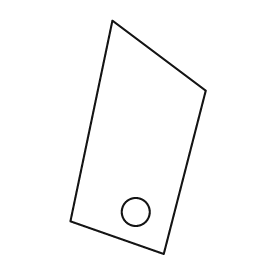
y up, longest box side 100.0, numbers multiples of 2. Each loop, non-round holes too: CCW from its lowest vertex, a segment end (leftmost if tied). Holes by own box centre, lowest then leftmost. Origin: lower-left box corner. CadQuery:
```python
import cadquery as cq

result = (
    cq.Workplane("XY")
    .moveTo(40.0, 0.0)
    .lineTo(58.0, 70.0)
    .lineTo(18.0, 100.0)
    .lineTo(0.0, 14.0)
    .close()
    .moveTo(28.0, 18.0)
    .circle(6.0)
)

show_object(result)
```